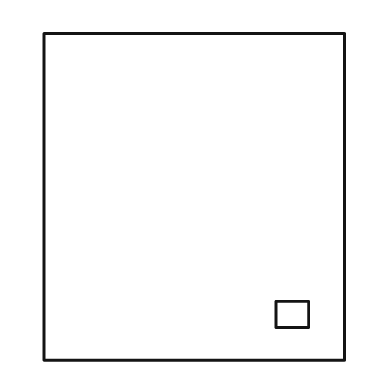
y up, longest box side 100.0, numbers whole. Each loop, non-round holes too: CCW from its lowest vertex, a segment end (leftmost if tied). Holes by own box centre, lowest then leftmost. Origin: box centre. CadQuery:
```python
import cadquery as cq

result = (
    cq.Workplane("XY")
    .moveTo(-46.0, -50.0)
    .lineTo(46.0, -50.0)
    .lineTo(46.0, 50.0)
    .lineTo(-46.0, 50.0)
    .close()
    .moveTo(25.0, -40.0)
    .lineTo(35.0, -40.0)
    .lineTo(35.0, -32.0)
    .lineTo(25.0, -32.0)
    .close()
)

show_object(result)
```